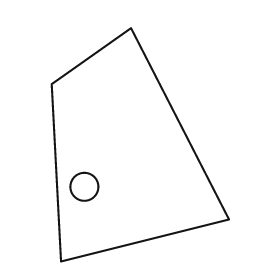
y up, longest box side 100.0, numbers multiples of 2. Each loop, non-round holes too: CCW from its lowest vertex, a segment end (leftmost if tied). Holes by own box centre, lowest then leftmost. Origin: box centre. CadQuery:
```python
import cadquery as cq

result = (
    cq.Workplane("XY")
    .moveTo(-34.0, -50.0)
    .lineTo(38.0, -32.0)
    .lineTo(-4.0, 50.0)
    .lineTo(-38.0, 26.0)
    .close()
    .moveTo(-24.0, -18.0)
    .circle(6.0)
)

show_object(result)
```